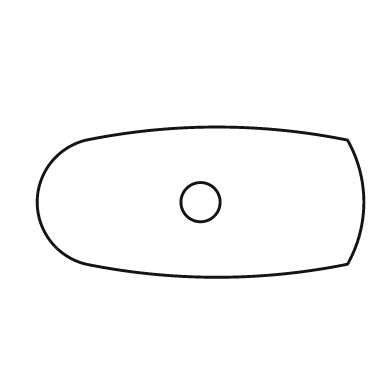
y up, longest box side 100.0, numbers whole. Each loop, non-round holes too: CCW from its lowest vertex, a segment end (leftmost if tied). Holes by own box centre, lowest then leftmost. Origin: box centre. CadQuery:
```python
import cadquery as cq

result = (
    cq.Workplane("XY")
    .moveTo(-35.0, -19.0)
    .threePointArc((5.0, -23.0), (45.0, -19.0))
    .threePointArc((50.0, 0.0), (45.0, 19.0))
    .threePointArc((5.0, 23.0), (-35.0, 19.0))
    .threePointArc((-50.0, 0.0), (-35.0, -19.0))
    .close()
    .moveTo(0.0, 0.0)
    .circle(6.0)
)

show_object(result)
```